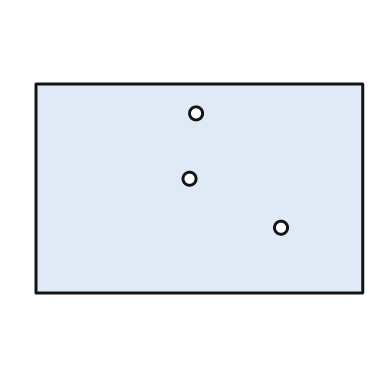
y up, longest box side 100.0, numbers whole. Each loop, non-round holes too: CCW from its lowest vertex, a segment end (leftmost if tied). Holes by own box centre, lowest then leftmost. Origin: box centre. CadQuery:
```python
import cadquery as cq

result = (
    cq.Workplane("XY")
    .moveTo(-50.0, -32.0)
    .lineTo(50.0, -32.0)
    .lineTo(50.0, 32.0)
    .lineTo(-50.0, 32.0)
    .close()
    .moveTo(25.0, -12.0)
    .circle(2.0)
    .moveTo(-3.0, 3.0)
    .circle(2.0)
    .moveTo(-1.0, 23.0)
    .circle(2.0)
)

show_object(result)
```